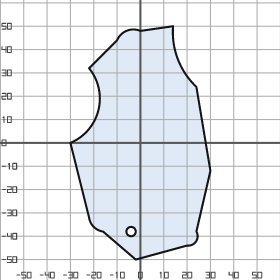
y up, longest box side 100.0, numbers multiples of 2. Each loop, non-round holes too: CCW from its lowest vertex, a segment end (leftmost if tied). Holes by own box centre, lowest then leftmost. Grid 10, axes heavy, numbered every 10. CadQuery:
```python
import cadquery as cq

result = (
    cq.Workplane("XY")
    .moveTo(-2.0, -50.0)
    .lineTo(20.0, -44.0)
    .threePointArc((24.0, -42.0), (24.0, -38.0))
    .lineTo(30.0, -12.0)
    .lineTo(24.0, 24.0)
    .threePointArc((16.0, 36.0), (14.0, 50.0))
    .lineTo(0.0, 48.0)
    .threePointArc((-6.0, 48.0), (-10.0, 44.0))
    .lineTo(-22.0, 32.0)
    .threePointArc((-18.0, 14.0), (-30.0, 0.0))
    .lineTo(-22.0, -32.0)
    .threePointArc((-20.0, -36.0), (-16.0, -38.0))
    .close()
    .moveTo(-4.0, -38.0)
    .circle(2.0)
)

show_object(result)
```